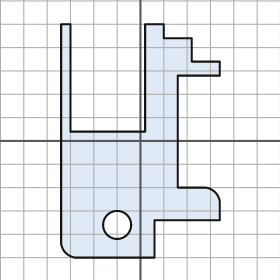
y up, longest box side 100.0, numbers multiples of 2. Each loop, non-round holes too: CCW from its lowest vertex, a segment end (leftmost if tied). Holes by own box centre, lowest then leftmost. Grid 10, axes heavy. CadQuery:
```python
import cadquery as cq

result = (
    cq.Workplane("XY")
    .moveTo(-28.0, -50.0)
    .lineTo(6.0, -50.0)
    .lineTo(6.0, -34.0)
    .lineTo(34.0, -34.0)
    .lineTo(34.0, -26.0)
    .threePointArc((32.0, -22.0), (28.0, -20.0))
    .lineTo(16.0, -20.0)
    .lineTo(16.0, 28.0)
    .lineTo(34.0, 28.0)
    .lineTo(34.0, 34.0)
    .lineTo(22.0, 34.0)
    .lineTo(22.0, 44.0)
    .lineTo(10.0, 44.0)
    .lineTo(10.0, 50.0)
    .lineTo(2.0, 50.0)
    .lineTo(2.0, 4.0)
    .lineTo(-30.0, 4.0)
    .lineTo(-30.0, 50.0)
    .lineTo(-34.0, 50.0)
    .lineTo(-34.0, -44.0)
    .threePointArc((-32.0, -48.0), (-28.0, -50.0))
    .close()
    .moveTo(-10.0, -36.0)
    .circle(6.0)
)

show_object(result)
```